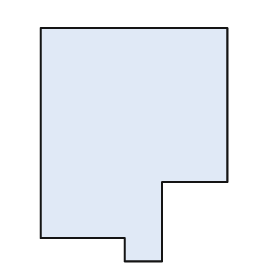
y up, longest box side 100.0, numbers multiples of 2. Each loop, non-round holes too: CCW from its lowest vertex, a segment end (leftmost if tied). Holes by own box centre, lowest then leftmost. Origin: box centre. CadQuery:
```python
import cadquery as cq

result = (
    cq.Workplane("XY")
    .moveTo(-4.0, -50.0)
    .lineTo(12.0, -50.0)
    .lineTo(12.0, -16.0)
    .lineTo(40.0, -16.0)
    .lineTo(40.0, 50.0)
    .lineTo(-40.0, 50.0)
    .lineTo(-40.0, -40.0)
    .lineTo(-4.0, -40.0)
    .close()
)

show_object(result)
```